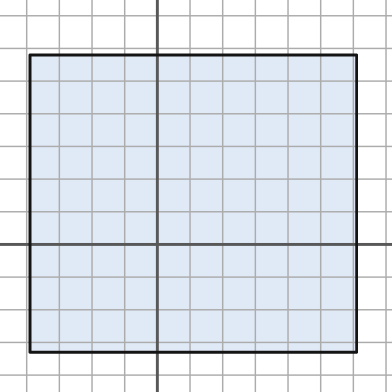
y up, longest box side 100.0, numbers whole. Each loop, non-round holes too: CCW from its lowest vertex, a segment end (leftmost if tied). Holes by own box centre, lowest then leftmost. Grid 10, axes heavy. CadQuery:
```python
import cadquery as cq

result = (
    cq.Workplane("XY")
    .moveTo(-39.0, -33.0)
    .lineTo(61.0, -33.0)
    .lineTo(61.0, 58.0)
    .lineTo(-39.0, 58.0)
    .close()
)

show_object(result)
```